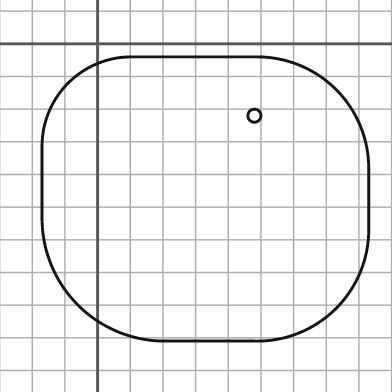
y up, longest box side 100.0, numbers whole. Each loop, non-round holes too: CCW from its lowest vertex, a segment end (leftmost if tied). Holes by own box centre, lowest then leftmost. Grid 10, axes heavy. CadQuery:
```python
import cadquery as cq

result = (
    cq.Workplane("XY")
    .moveTo(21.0, -91.0)
    .lineTo(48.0, -91.0)
    .threePointArc((73.0, -81.0), (83.0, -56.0))
    .lineTo(83.0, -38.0)
    .threePointArc((73.0, -14.0), (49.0, -4.0))
    .lineTo(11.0, -4.0)
    .threePointArc((-9.0, -12.0), (-17.0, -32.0))
    .lineTo(-17.0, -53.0)
    .threePointArc((-6.0, -80.0), (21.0, -91.0))
    .close()
    .moveTo(48.0, -22.0)
    .circle(2.0)
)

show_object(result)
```